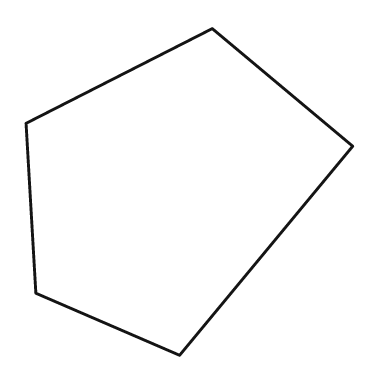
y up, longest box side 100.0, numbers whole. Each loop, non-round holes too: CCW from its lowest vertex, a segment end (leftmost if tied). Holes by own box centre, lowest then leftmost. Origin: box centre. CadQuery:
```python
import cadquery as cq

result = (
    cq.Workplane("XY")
    .moveTo(-3.0, -50.0)
    .lineTo(50.0, 14.0)
    .lineTo(7.0, 50.0)
    .lineTo(-50.0, 21.0)
    .lineTo(-47.0, -31.0)
    .close()
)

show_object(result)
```